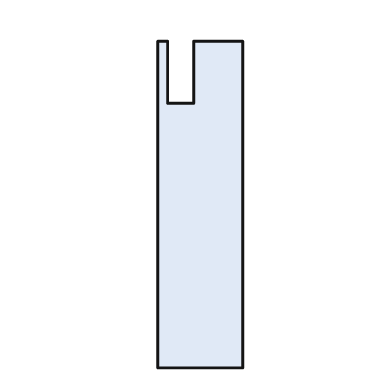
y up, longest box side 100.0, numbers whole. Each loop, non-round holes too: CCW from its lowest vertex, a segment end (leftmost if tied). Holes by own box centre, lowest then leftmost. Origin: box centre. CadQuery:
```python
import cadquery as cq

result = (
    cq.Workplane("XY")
    .moveTo(-13.0, -50.0)
    .lineTo(13.0, -50.0)
    .lineTo(13.0, 50.0)
    .lineTo(-2.0, 50.0)
    .lineTo(-2.0, 31.0)
    .lineTo(-10.0, 31.0)
    .lineTo(-10.0, 50.0)
    .lineTo(-13.0, 50.0)
    .close()
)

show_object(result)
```